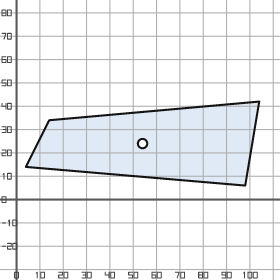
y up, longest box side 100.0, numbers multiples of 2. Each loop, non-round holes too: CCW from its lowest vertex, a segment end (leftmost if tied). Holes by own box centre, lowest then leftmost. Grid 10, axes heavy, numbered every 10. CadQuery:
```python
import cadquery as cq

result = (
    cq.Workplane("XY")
    .moveTo(98.0, 6.0)
    .lineTo(104.0, 42.0)
    .lineTo(14.0, 34.0)
    .lineTo(4.0, 14.0)
    .close()
    .moveTo(54.0, 24.0)
    .circle(2.0)
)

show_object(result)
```